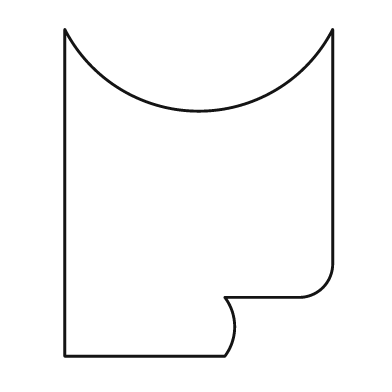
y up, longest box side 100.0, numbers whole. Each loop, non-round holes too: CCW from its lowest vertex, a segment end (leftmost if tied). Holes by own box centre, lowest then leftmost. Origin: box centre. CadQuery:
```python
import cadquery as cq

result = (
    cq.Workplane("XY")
    .moveTo(-41.0, -50.0)
    .lineTo(8.0, -50.0)
    .threePointArc((11.0, -41.0), (8.0, -32.0))
    .lineTo(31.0, -32.0)
    .threePointArc((38.0, -29.0), (41.0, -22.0))
    .lineTo(41.0, 50.0)
    .threePointArc((0.0, 25.0), (-41.0, 50.0))
    .close()
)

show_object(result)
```